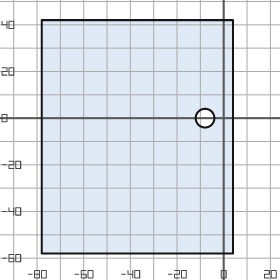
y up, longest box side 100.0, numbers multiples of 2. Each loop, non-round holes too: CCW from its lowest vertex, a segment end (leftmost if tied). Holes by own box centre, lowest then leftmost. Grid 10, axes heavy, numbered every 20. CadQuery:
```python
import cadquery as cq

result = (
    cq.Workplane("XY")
    .moveTo(-78.0, -58.0)
    .lineTo(4.0, -58.0)
    .lineTo(4.0, 42.0)
    .lineTo(-78.0, 42.0)
    .close()
    .moveTo(-8.0, 0.0)
    .circle(4.0)
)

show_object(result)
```